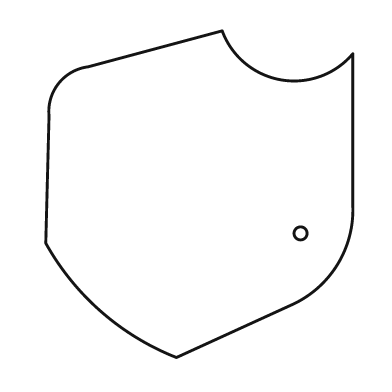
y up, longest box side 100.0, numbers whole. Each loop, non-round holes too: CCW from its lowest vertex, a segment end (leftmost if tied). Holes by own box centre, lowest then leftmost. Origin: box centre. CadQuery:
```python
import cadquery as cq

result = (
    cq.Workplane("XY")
    .moveTo(-7.0, -50.0)
    .lineTo(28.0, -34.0)
    .threePointArc((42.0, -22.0), (47.0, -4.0))
    .lineTo(47.0, 43.0)
    .threePointArc((25.0, 35.0), (7.0, 50.0))
    .lineTo(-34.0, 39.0)
    .threePointArc((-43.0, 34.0), (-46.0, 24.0))
    .lineTo(-47.0, -15.0)
    .threePointArc((-30.0, -36.0), (-7.0, -50.0))
    .close()
    .moveTo(31.0, -12.0)
    .circle(2.0)
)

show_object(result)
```